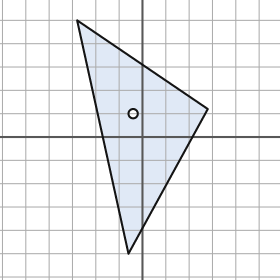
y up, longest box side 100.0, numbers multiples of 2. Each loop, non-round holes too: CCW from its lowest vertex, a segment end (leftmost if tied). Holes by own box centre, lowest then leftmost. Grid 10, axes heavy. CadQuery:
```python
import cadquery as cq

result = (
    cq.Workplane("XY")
    .moveTo(-6.0, -50.0)
    .lineTo(28.0, 12.0)
    .lineTo(-28.0, 50.0)
    .close()
    .moveTo(-4.0, 10.0)
    .circle(2.0)
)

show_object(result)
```